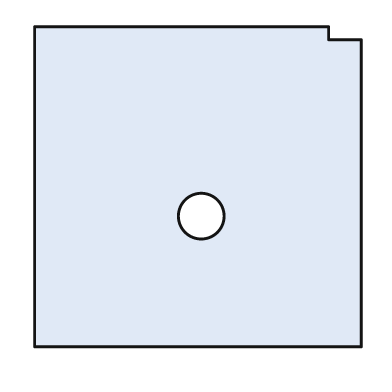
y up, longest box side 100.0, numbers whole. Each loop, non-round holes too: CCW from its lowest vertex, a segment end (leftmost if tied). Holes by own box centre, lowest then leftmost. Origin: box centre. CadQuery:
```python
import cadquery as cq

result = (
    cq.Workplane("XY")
    .moveTo(-50.0, -49.0)
    .lineTo(50.0, -49.0)
    .lineTo(50.0, 45.0)
    .lineTo(40.0, 45.0)
    .lineTo(40.0, 49.0)
    .lineTo(-50.0, 49.0)
    .close()
    .moveTo(1.0, -9.0)
    .circle(7.0)
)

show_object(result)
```